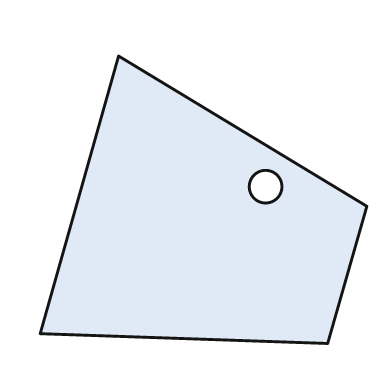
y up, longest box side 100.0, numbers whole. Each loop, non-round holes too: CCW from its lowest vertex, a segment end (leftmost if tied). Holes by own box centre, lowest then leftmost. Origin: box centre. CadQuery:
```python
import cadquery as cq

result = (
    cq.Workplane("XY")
    .moveTo(38.0, -44.0)
    .lineTo(50.0, -2.0)
    .lineTo(-26.0, 44.0)
    .lineTo(-50.0, -41.0)
    .close()
    .moveTo(19.0, 4.0)
    .circle(5.0)
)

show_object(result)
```